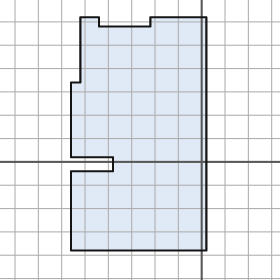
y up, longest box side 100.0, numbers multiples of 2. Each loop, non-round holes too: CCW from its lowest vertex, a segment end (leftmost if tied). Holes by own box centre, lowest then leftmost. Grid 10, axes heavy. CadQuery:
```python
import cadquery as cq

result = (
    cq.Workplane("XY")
    .moveTo(-56.0, -38.0)
    .lineTo(2.0, -38.0)
    .lineTo(2.0, 62.0)
    .lineTo(-22.0, 62.0)
    .lineTo(-22.0, 58.0)
    .lineTo(-44.0, 58.0)
    .lineTo(-44.0, 62.0)
    .lineTo(-52.0, 62.0)
    .lineTo(-52.0, 34.0)
    .lineTo(-56.0, 34.0)
    .lineTo(-56.0, 2.0)
    .lineTo(-38.0, 2.0)
    .lineTo(-38.0, -4.0)
    .lineTo(-56.0, -4.0)
    .close()
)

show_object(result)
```